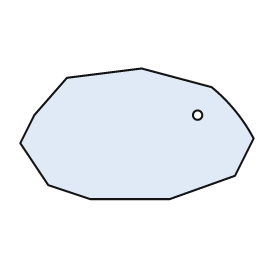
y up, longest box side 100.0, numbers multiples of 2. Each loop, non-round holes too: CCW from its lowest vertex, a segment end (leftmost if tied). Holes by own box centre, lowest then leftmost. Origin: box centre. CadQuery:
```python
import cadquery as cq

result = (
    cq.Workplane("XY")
    .moveTo(-20.0, -28.0)
    .lineTo(14.0, -28.0)
    .lineTo(42.0, -18.0)
    .lineTo(50.0, -2.0)
    .threePointArc((42.0, 10.0), (32.0, 20.0))
    .lineTo(2.0, 28.0)
    .lineTo(-30.0, 24.0)
    .lineTo(-44.0, 8.0)
    .lineTo(-50.0, -4.0)
    .lineTo(-38.0, -22.0)
    .close()
    .moveTo(26.0, 8.0)
    .circle(2.0)
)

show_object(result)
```